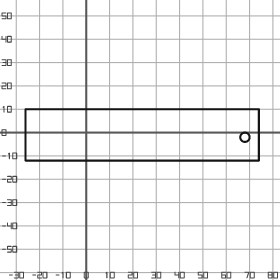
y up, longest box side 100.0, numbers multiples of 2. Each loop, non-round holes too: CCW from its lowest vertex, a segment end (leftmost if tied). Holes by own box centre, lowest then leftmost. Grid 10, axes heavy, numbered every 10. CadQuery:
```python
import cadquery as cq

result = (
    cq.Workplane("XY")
    .moveTo(-26.0, -12.0)
    .lineTo(74.0, -12.0)
    .lineTo(74.0, 10.0)
    .lineTo(-26.0, 10.0)
    .close()
    .moveTo(68.0, -2.0)
    .circle(2.0)
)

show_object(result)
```